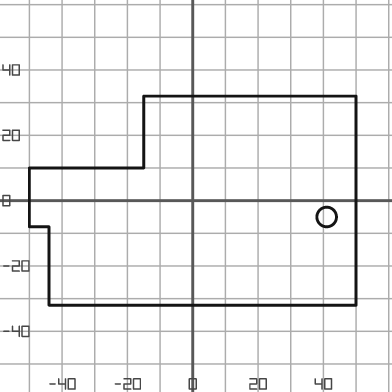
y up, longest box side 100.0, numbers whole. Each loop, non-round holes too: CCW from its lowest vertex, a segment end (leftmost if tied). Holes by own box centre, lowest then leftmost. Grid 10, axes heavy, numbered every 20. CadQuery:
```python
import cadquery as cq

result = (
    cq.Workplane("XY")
    .moveTo(-44.0, -32.0)
    .lineTo(50.0, -32.0)
    .lineTo(50.0, 32.0)
    .lineTo(-15.0, 32.0)
    .lineTo(-15.0, 10.0)
    .lineTo(-50.0, 10.0)
    .lineTo(-50.0, -8.0)
    .lineTo(-44.0, -8.0)
    .close()
    .moveTo(41.0, -5.0)
    .circle(3.0)
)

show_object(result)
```